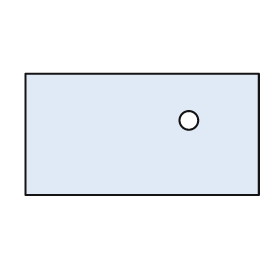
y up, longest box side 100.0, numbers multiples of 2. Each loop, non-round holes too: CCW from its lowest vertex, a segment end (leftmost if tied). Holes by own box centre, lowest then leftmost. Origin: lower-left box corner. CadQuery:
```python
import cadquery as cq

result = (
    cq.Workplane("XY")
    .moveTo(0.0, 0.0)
    .lineTo(100.0, 0.0)
    .lineTo(100.0, 52.0)
    .lineTo(0.0, 52.0)
    .close()
    .moveTo(70.0, 32.0)
    .circle(4.0)
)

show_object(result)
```